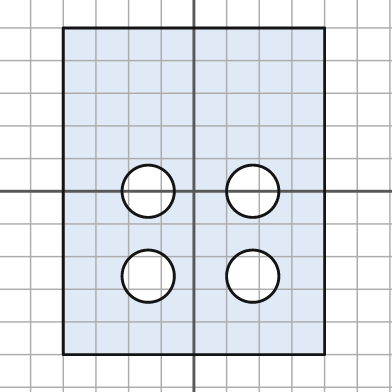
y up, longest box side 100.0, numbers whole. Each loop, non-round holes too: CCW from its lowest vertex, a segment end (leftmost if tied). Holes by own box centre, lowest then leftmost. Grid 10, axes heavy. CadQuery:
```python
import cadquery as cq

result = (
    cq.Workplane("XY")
    .moveTo(-40.0, -50.0)
    .lineTo(40.0, -50.0)
    .lineTo(40.0, 50.0)
    .lineTo(-40.0, 50.0)
    .close()
    .moveTo(-14.0, -26.0)
    .circle(8.0)
    .moveTo(18.0, -26.0)
    .circle(8.0)
    .moveTo(-14.0, 0.0)
    .circle(8.0)
    .moveTo(18.0, 0.0)
    .circle(8.0)
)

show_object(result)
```